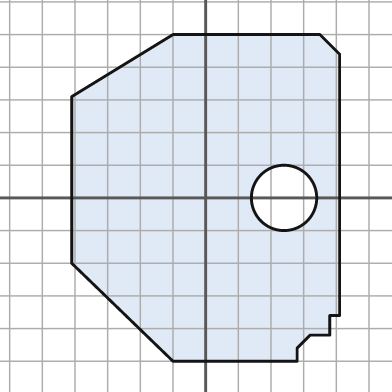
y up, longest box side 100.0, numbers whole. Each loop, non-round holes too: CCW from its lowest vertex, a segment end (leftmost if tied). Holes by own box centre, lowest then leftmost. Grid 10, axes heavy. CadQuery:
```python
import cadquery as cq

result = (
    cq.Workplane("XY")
    .moveTo(-10.0, -50.0)
    .lineTo(28.0, -50.0)
    .lineTo(28.0, -46.0)
    .lineTo(32.0, -42.0)
    .lineTo(38.0, -42.0)
    .lineTo(38.0, -36.0)
    .lineTo(41.0, -36.0)
    .lineTo(41.0, 44.0)
    .lineTo(35.0, 50.0)
    .lineTo(-10.0, 50.0)
    .lineTo(-41.0, 31.0)
    .lineTo(-41.0, -20.0)
    .close()
    .moveTo(24.0, 0.0)
    .circle(10.0)
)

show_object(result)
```